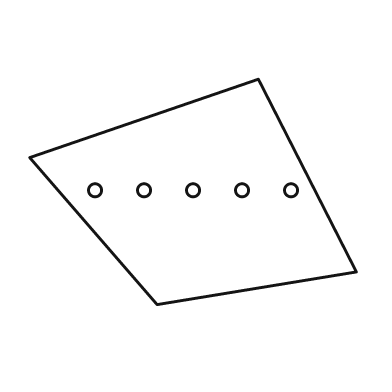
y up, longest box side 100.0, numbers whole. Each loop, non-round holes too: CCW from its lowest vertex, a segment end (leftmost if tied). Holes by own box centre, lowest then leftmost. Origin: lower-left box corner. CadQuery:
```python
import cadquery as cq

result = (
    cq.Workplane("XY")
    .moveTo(39.0, 0.0)
    .lineTo(100.0, 10.0)
    .lineTo(70.0, 69.0)
    .lineTo(0.0, 45.0)
    .close()
    .moveTo(20.0, 35.0)
    .circle(2.0)
    .moveTo(35.0, 35.0)
    .circle(2.0)
    .moveTo(50.0, 35.0)
    .circle(2.0)
    .moveTo(65.0, 35.0)
    .circle(2.0)
    .moveTo(80.0, 35.0)
    .circle(2.0)
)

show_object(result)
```